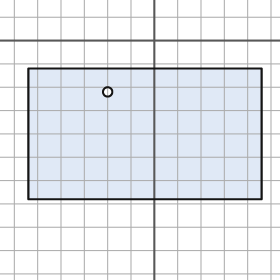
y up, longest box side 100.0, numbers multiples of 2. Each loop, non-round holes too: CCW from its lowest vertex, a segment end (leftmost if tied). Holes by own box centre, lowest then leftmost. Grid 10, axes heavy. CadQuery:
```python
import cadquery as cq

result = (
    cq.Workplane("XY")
    .moveTo(-54.0, -68.0)
    .lineTo(46.0, -68.0)
    .lineTo(46.0, -12.0)
    .lineTo(-54.0, -12.0)
    .close()
    .moveTo(-20.0, -22.0)
    .circle(2.0)
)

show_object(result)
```